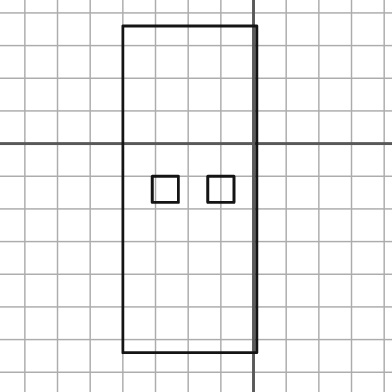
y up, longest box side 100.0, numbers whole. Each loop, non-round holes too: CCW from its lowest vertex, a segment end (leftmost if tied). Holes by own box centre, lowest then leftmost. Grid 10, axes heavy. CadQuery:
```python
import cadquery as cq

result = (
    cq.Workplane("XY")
    .moveTo(-40.0, -64.0)
    .lineTo(1.0, -64.0)
    .lineTo(1.0, 36.0)
    .lineTo(-40.0, 36.0)
    .close()
    .moveTo(-31.0, -18.0)
    .lineTo(-23.0, -18.0)
    .lineTo(-23.0, -10.0)
    .lineTo(-31.0, -10.0)
    .close()
    .moveTo(-14.0, -18.0)
    .lineTo(-6.0, -18.0)
    .lineTo(-6.0, -10.0)
    .lineTo(-14.0, -10.0)
    .close()
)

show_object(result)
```